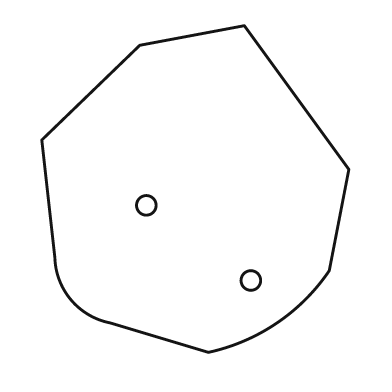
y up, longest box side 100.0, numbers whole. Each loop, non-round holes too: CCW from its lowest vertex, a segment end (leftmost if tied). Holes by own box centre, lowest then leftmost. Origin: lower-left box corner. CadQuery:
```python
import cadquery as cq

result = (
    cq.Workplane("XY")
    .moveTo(51.0, 0.0)
    .threePointArc((72.0, 9.0), (88.0, 25.0))
    .lineTo(94.0, 56.0)
    .lineTo(62.0, 100.0)
    .lineTo(30.0, 94.0)
    .lineTo(0.0, 65.0)
    .lineTo(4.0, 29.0)
    .threePointArc((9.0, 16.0), (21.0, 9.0))
    .close()
    .moveTo(64.0, 22.0)
    .circle(3.0)
    .moveTo(32.0, 45.0)
    .circle(3.0)
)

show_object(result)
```